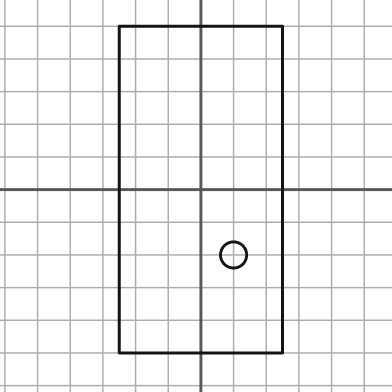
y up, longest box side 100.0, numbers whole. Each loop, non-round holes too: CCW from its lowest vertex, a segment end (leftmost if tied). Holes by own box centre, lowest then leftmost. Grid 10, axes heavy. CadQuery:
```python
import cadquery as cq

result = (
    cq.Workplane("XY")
    .moveTo(-25.0, -50.0)
    .lineTo(25.0, -50.0)
    .lineTo(25.0, 50.0)
    .lineTo(-25.0, 50.0)
    .close()
    .moveTo(10.0, -20.0)
    .circle(4.0)
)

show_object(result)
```